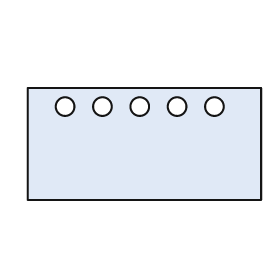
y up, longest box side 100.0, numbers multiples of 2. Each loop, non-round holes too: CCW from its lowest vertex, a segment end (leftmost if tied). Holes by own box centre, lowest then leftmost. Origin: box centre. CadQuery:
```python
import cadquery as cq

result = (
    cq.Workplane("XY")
    .moveTo(-50.0, -24.0)
    .lineTo(50.0, -24.0)
    .lineTo(50.0, 24.0)
    .lineTo(-50.0, 24.0)
    .close()
    .moveTo(-34.0, 16.0)
    .circle(4.0)
    .moveTo(-18.0, 16.0)
    .circle(4.0)
    .moveTo(-2.0, 16.0)
    .circle(4.0)
    .moveTo(14.0, 16.0)
    .circle(4.0)
    .moveTo(30.0, 16.0)
    .circle(4.0)
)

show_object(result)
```